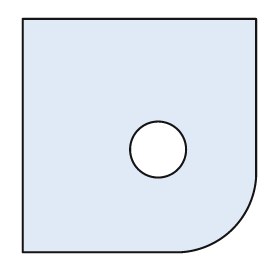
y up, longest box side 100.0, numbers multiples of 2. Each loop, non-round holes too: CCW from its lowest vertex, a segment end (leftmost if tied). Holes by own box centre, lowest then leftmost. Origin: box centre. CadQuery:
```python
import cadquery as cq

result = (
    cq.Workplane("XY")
    .moveTo(-50.0, -50.0)
    .lineTo(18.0, -50.0)
    .threePointArc((40.0, -40.0), (50.0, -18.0))
    .lineTo(50.0, 50.0)
    .lineTo(-50.0, 50.0)
    .close()
    .moveTo(8.0, -6.0)
    .circle(12.0)
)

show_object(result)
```